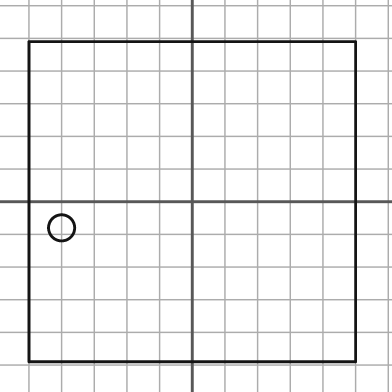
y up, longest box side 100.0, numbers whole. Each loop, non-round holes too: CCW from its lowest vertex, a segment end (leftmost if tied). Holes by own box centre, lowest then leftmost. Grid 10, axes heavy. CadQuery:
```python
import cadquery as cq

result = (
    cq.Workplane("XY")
    .moveTo(-50.0, -49.0)
    .lineTo(50.0, -49.0)
    .lineTo(50.0, 49.0)
    .lineTo(-50.0, 49.0)
    .close()
    .moveTo(-40.0, -8.0)
    .circle(4.0)
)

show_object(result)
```